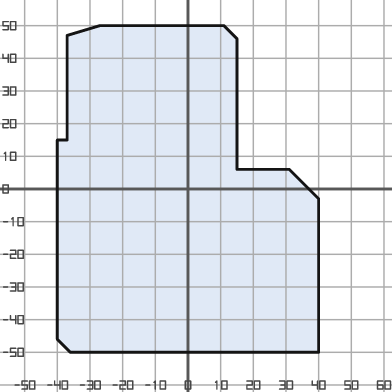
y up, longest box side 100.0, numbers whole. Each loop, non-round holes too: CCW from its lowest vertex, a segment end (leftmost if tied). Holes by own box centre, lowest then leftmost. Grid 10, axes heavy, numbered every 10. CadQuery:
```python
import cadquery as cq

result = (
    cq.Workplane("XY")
    .moveTo(-36.0, -50.0)
    .lineTo(40.0, -50.0)
    .lineTo(40.0, -3.0)
    .lineTo(31.0, 6.0)
    .lineTo(15.0, 6.0)
    .lineTo(15.0, 46.0)
    .lineTo(11.0, 50.0)
    .lineTo(-27.0, 50.0)
    .lineTo(-37.0, 47.0)
    .lineTo(-37.0, 15.0)
    .lineTo(-40.0, 15.0)
    .lineTo(-40.0, -46.0)
    .close()
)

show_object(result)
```